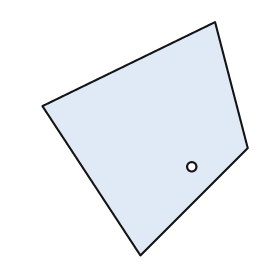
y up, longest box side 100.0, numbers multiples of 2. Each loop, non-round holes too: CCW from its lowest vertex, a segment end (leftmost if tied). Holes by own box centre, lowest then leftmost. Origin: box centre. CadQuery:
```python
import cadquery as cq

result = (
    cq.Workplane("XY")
    .moveTo(-2.0, -50.0)
    .lineTo(44.0, -4.0)
    .lineTo(30.0, 50.0)
    .lineTo(-44.0, 14.0)
    .close()
    .moveTo(20.0, -12.0)
    .circle(2.0)
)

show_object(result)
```